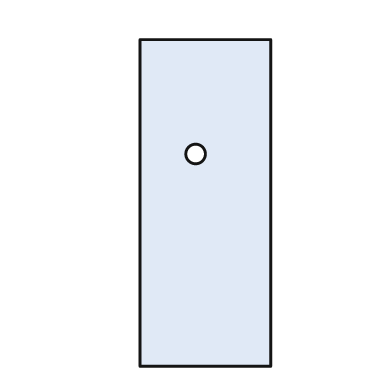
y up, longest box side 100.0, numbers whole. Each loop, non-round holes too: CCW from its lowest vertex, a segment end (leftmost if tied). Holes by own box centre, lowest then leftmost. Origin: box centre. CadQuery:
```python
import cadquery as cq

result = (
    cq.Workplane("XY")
    .moveTo(-20.0, -50.0)
    .lineTo(20.0, -50.0)
    .lineTo(20.0, 50.0)
    .lineTo(-20.0, 50.0)
    .close()
    .moveTo(-3.0, 15.0)
    .circle(3.0)
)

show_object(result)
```